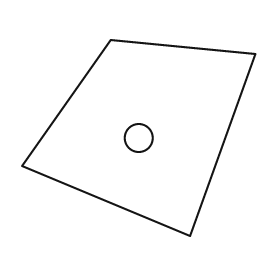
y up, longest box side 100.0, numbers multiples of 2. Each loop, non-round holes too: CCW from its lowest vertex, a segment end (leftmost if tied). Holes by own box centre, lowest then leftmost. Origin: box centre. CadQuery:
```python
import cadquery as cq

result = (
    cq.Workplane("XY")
    .moveTo(22.0, -42.0)
    .lineTo(50.0, 36.0)
    .lineTo(-12.0, 42.0)
    .lineTo(-50.0, -12.0)
    .close()
    .moveTo(0.0, 0.0)
    .circle(6.0)
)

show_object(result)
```